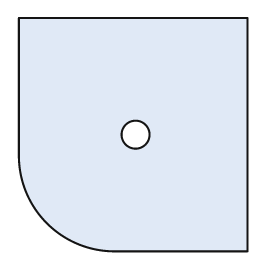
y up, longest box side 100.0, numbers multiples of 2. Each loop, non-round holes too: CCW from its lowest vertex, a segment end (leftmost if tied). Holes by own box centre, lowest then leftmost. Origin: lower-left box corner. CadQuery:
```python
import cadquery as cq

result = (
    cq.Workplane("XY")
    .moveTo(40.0, 0.0)
    .lineTo(98.0, 0.0)
    .lineTo(98.0, 100.0)
    .lineTo(0.0, 100.0)
    .lineTo(0.0, 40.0)
    .threePointArc((12.0, 12.0), (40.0, 0.0))
    .close()
    .moveTo(50.0, 50.0)
    .circle(6.0)
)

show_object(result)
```